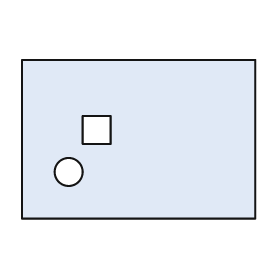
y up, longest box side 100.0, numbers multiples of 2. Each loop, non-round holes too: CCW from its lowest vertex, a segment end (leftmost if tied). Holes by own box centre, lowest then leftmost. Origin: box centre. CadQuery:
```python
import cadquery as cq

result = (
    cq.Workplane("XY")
    .moveTo(-50.0, -34.0)
    .lineTo(50.0, -34.0)
    .lineTo(50.0, 34.0)
    .lineTo(-50.0, 34.0)
    .close()
    .moveTo(-30.0, -14.0)
    .circle(6.0)
    .moveTo(-24.0, -2.0)
    .lineTo(-12.0, -2.0)
    .lineTo(-12.0, 10.0)
    .lineTo(-24.0, 10.0)
    .close()
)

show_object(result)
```